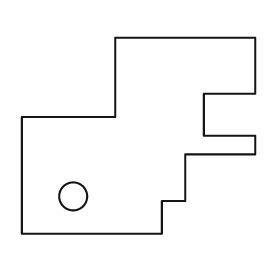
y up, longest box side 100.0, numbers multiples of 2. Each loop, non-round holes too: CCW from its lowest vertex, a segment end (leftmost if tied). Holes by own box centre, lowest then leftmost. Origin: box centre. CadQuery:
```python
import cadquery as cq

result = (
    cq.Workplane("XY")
    .moveTo(-50.0, -42.0)
    .lineTo(10.0, -42.0)
    .lineTo(10.0, -28.0)
    .lineTo(20.0, -28.0)
    .lineTo(20.0, -8.0)
    .lineTo(50.0, -8.0)
    .lineTo(50.0, 0.0)
    .lineTo(28.0, 0.0)
    .lineTo(28.0, 18.0)
    .lineTo(50.0, 18.0)
    .lineTo(50.0, 42.0)
    .lineTo(-10.0, 42.0)
    .lineTo(-10.0, 8.0)
    .lineTo(-50.0, 8.0)
    .close()
    .moveTo(-28.0, -26.0)
    .circle(6.0)
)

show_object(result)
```